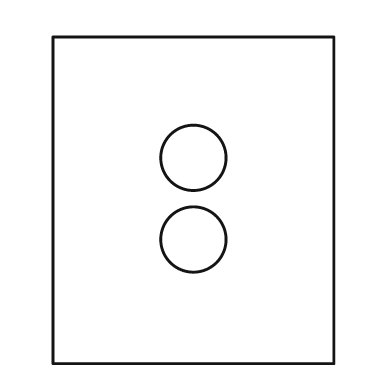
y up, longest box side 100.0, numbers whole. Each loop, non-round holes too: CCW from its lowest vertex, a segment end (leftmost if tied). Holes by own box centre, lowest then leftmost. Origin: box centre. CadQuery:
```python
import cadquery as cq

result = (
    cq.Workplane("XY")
    .moveTo(-43.0, -50.0)
    .lineTo(43.0, -50.0)
    .lineTo(43.0, 50.0)
    .lineTo(-43.0, 50.0)
    .close()
    .moveTo(0.0, -12.0)
    .circle(10.0)
    .moveTo(0.0, 13.0)
    .circle(10.0)
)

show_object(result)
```